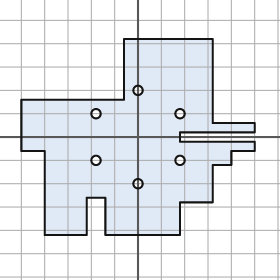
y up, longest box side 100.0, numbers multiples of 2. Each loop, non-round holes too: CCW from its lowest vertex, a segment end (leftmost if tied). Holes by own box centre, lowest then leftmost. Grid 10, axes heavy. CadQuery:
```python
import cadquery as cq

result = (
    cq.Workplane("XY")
    .moveTo(-40.0, -42.0)
    .lineTo(-22.0, -42.0)
    .lineTo(-22.0, -26.0)
    .lineTo(-14.0, -26.0)
    .lineTo(-14.0, -42.0)
    .lineTo(18.0, -42.0)
    .lineTo(18.0, -28.0)
    .lineTo(32.0, -28.0)
    .lineTo(32.0, -12.0)
    .lineTo(40.0, -12.0)
    .lineTo(40.0, -6.0)
    .lineTo(50.0, -6.0)
    .lineTo(50.0, -2.0)
    .lineTo(18.0, -2.0)
    .lineTo(18.0, 2.0)
    .lineTo(50.0, 2.0)
    .lineTo(50.0, 6.0)
    .lineTo(32.0, 6.0)
    .lineTo(32.0, 42.0)
    .lineTo(-6.0, 42.0)
    .lineTo(-6.0, 16.0)
    .lineTo(-50.0, 16.0)
    .lineTo(-50.0, -6.0)
    .lineTo(-40.0, -6.0)
    .close()
    .moveTo(0.0, -20.0)
    .circle(2.0)
    .moveTo(-18.0, -10.0)
    .circle(2.0)
    .moveTo(18.0, -10.0)
    .circle(2.0)
    .moveTo(-18.0, 10.0)
    .circle(2.0)
    .moveTo(18.0, 10.0)
    .circle(2.0)
    .moveTo(0.0, 20.0)
    .circle(2.0)
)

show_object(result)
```